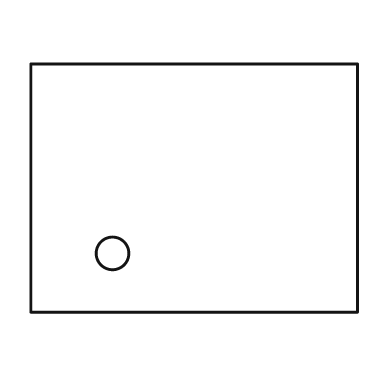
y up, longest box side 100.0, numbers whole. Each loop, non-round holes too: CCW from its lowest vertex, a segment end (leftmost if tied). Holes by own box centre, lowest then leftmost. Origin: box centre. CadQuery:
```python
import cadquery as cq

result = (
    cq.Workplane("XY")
    .moveTo(-50.0, -38.0)
    .lineTo(50.0, -38.0)
    .lineTo(50.0, 38.0)
    .lineTo(-50.0, 38.0)
    .close()
    .moveTo(-25.0, -20.0)
    .circle(5.0)
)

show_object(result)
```